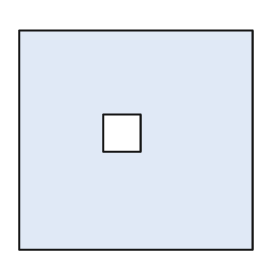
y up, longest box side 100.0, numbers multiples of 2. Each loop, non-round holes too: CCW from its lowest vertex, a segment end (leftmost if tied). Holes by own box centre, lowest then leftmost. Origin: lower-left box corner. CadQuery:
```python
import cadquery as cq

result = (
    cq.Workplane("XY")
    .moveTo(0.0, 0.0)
    .lineTo(100.0, 0.0)
    .lineTo(100.0, 94.0)
    .lineTo(0.0, 94.0)
    .close()
    .moveTo(36.0, 42.0)
    .lineTo(52.0, 42.0)
    .lineTo(52.0, 58.0)
    .lineTo(36.0, 58.0)
    .close()
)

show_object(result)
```